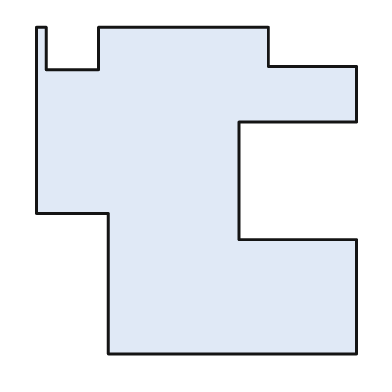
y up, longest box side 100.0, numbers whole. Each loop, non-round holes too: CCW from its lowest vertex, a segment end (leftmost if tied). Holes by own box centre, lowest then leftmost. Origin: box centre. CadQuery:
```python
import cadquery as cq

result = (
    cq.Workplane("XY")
    .moveTo(-27.0, -50.0)
    .lineTo(49.0, -50.0)
    .lineTo(49.0, -15.0)
    .lineTo(13.0, -15.0)
    .lineTo(13.0, 21.0)
    .lineTo(49.0, 21.0)
    .lineTo(49.0, 38.0)
    .lineTo(22.0, 38.0)
    .lineTo(22.0, 50.0)
    .lineTo(-30.0, 50.0)
    .lineTo(-30.0, 37.0)
    .lineTo(-46.0, 37.0)
    .lineTo(-46.0, 50.0)
    .lineTo(-49.0, 50.0)
    .lineTo(-49.0, -7.0)
    .lineTo(-27.0, -7.0)
    .close()
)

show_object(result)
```